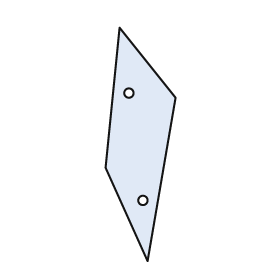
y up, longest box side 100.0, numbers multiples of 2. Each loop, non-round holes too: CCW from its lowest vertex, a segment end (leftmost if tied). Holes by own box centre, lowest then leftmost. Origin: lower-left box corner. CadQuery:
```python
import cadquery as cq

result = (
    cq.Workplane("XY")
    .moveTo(18.0, 0.0)
    .lineTo(30.0, 70.0)
    .lineTo(6.0, 100.0)
    .lineTo(0.0, 40.0)
    .close()
    .moveTo(16.0, 26.0)
    .circle(2.0)
    .moveTo(10.0, 72.0)
    .circle(2.0)
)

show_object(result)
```